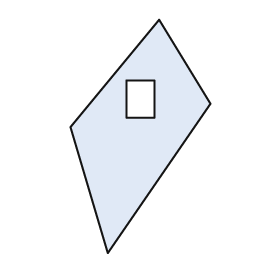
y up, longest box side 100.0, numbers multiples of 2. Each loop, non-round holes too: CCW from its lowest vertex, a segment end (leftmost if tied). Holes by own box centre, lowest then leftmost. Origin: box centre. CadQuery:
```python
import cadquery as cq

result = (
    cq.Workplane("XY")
    .moveTo(-14.0, -50.0)
    .lineTo(30.0, 14.0)
    .lineTo(8.0, 50.0)
    .lineTo(-30.0, 4.0)
    .close()
    .moveTo(-6.0, 8.0)
    .lineTo(6.0, 8.0)
    .lineTo(6.0, 24.0)
    .lineTo(-6.0, 24.0)
    .close()
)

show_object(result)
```